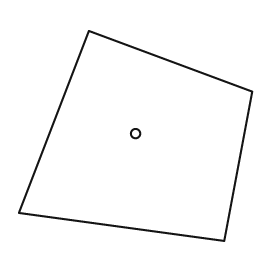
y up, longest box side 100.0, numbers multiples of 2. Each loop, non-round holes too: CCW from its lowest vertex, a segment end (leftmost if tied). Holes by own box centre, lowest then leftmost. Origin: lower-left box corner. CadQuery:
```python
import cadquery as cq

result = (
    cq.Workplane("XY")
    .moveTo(88.0, 0.0)
    .lineTo(100.0, 64.0)
    .lineTo(30.0, 90.0)
    .lineTo(0.0, 12.0)
    .close()
    .moveTo(50.0, 46.0)
    .circle(2.0)
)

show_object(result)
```